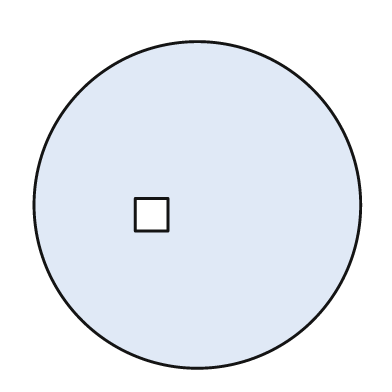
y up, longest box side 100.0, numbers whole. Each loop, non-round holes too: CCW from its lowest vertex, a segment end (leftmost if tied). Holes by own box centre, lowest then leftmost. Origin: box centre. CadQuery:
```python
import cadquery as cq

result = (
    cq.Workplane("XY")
    .moveTo(0.0, 0.0)
    .circle(50.0)
    .moveTo(-19.0, -8.0)
    .lineTo(-9.0, -8.0)
    .lineTo(-9.0, 2.0)
    .lineTo(-19.0, 2.0)
    .close()
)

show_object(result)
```